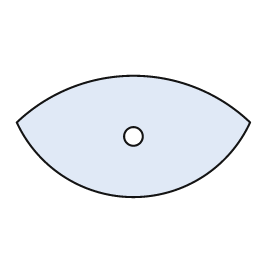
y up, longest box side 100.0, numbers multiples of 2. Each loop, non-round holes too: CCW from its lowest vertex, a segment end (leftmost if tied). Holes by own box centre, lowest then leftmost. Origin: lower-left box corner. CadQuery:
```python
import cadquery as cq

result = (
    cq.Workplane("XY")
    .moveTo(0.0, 32.0)
    .threePointArc((50.0, 0.0), (100.0, 32.0))
    .threePointArc((50.0, 52.0), (0.0, 32.0))
    .close()
    .moveTo(50.0, 26.0)
    .circle(4.0)
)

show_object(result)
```